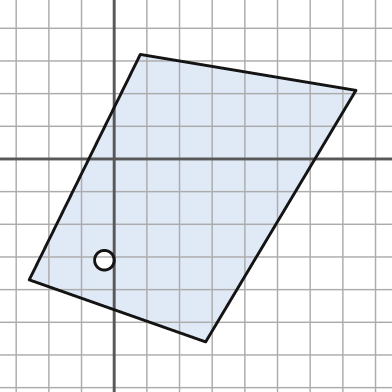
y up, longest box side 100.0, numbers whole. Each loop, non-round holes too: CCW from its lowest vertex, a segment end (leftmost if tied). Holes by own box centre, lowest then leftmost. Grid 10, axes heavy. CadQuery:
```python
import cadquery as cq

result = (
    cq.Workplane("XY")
    .moveTo(28.0, -56.0)
    .lineTo(74.0, 21.0)
    .lineTo(8.0, 32.0)
    .lineTo(-26.0, -37.0)
    .close()
    .moveTo(-3.0, -31.0)
    .circle(3.0)
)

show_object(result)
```